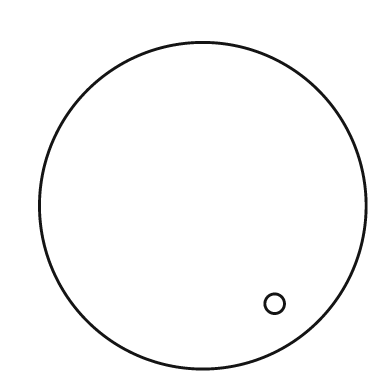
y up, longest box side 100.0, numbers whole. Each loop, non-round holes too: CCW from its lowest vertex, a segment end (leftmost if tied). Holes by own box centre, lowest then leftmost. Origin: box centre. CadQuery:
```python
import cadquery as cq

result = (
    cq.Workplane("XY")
    .moveTo(0.0, 0.0)
    .circle(50.0)
    .moveTo(22.0, -30.0)
    .circle(3.0)
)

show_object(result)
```